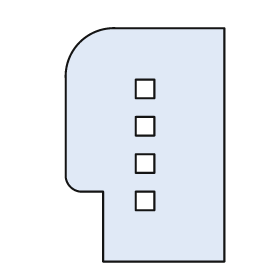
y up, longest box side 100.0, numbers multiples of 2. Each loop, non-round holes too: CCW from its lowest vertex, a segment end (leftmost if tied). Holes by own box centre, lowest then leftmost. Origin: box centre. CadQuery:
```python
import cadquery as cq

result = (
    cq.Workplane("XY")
    .moveTo(-18.0, -50.0)
    .lineTo(34.0, -50.0)
    .lineTo(34.0, 50.0)
    .lineTo(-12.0, 50.0)
    .threePointArc((-28.0, 44.0), (-34.0, 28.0))
    .lineTo(-34.0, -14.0)
    .threePointArc((-32.0, -18.0), (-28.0, -20.0))
    .lineTo(-18.0, -20.0)
    .close()
    .moveTo(-4.0, -28.0)
    .lineTo(4.0, -28.0)
    .lineTo(4.0, -20.0)
    .lineTo(-4.0, -20.0)
    .close()
    .moveTo(-4.0, -12.0)
    .lineTo(4.0, -12.0)
    .lineTo(4.0, -4.0)
    .lineTo(-4.0, -4.0)
    .close()
    .moveTo(-4.0, 4.0)
    .lineTo(4.0, 4.0)
    .lineTo(4.0, 12.0)
    .lineTo(-4.0, 12.0)
    .close()
    .moveTo(-4.0, 20.0)
    .lineTo(4.0, 20.0)
    .lineTo(4.0, 28.0)
    .lineTo(-4.0, 28.0)
    .close()
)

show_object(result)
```